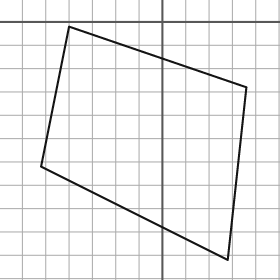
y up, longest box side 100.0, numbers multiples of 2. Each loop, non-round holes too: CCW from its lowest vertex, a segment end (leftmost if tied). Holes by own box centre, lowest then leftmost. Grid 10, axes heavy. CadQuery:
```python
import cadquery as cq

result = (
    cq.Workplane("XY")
    .moveTo(28.0, -102.0)
    .lineTo(36.0, -28.0)
    .lineTo(-40.0, -2.0)
    .lineTo(-52.0, -62.0)
    .close()
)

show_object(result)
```